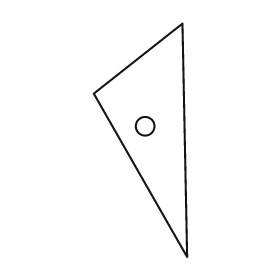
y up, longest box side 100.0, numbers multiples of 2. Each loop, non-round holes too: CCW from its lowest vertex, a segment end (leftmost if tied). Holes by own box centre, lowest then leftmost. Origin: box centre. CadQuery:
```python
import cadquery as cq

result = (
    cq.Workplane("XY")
    .moveTo(20.0, -50.0)
    .lineTo(18.0, 50.0)
    .lineTo(-20.0, 20.0)
    .close()
    .moveTo(2.0, 6.0)
    .circle(4.0)
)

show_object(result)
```